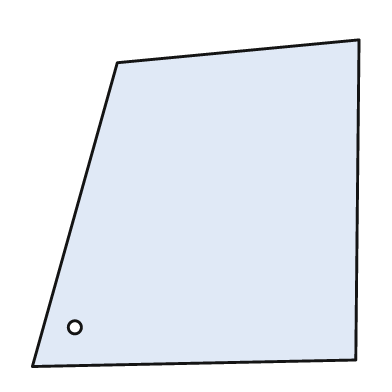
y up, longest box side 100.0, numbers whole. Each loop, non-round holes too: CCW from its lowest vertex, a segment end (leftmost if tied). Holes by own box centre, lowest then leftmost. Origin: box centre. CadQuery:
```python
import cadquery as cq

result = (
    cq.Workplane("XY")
    .moveTo(-50.0, -50.0)
    .lineTo(49.0, -48.0)
    .lineTo(50.0, 50.0)
    .lineTo(-24.0, 43.0)
    .close()
    .moveTo(-37.0, -38.0)
    .circle(2.0)
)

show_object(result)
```